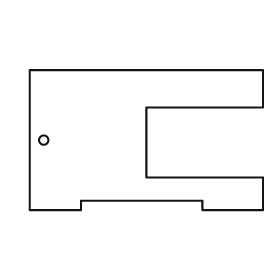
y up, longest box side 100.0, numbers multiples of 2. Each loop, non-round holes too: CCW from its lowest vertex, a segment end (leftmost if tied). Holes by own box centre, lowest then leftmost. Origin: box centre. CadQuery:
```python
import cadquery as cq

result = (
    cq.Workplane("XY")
    .moveTo(-50.0, -30.0)
    .lineTo(-28.0, -30.0)
    .lineTo(-28.0, -26.0)
    .lineTo(24.0, -26.0)
    .lineTo(24.0, -30.0)
    .lineTo(50.0, -30.0)
    .lineTo(50.0, -16.0)
    .lineTo(0.0, -16.0)
    .lineTo(0.0, 14.0)
    .lineTo(50.0, 14.0)
    .lineTo(50.0, 30.0)
    .lineTo(-50.0, 30.0)
    .close()
    .moveTo(-44.0, 0.0)
    .circle(2.0)
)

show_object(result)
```